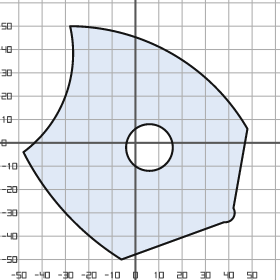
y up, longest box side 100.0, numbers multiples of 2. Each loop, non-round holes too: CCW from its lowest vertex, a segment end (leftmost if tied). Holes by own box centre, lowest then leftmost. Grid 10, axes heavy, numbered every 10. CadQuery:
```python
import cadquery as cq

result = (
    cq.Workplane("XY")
    .moveTo(-6.0, -50.0)
    .lineTo(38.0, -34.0)
    .threePointArc((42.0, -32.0), (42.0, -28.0))
    .lineTo(48.0, 6.0)
    .threePointArc((16.0, 38.0), (-28.0, 50.0))
    .threePointArc((-30.0, 20.0), (-48.0, -4.0))
    .threePointArc((-30.0, -30.0), (-6.0, -50.0))
    .close()
    .moveTo(6.0, -2.0)
    .circle(10.0)
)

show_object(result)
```